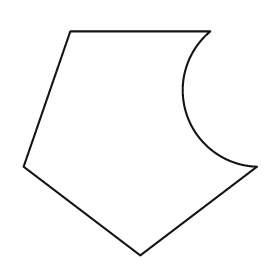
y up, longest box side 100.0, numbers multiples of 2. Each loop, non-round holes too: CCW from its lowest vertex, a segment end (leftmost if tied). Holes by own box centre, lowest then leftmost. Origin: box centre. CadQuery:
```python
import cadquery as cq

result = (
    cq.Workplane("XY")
    .moveTo(0.0, -48.0)
    .lineTo(50.0, -10.0)
    .threePointArc((20.0, 12.0), (30.0, 48.0))
    .lineTo(-30.0, 48.0)
    .lineTo(-50.0, -10.0)
    .close()
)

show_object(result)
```